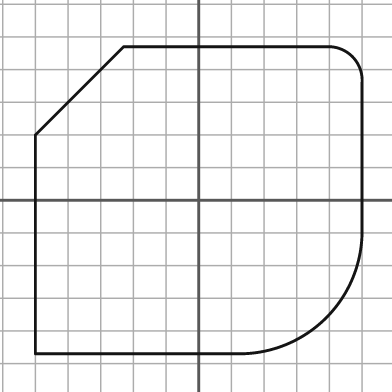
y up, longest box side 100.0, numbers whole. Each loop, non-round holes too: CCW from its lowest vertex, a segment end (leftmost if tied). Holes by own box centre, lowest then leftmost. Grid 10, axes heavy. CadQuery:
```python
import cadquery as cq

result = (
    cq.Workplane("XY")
    .moveTo(-50.0, -47.0)
    .lineTo(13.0, -47.0)
    .threePointArc((39.0, -36.0), (50.0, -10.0))
    .lineTo(50.0, 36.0)
    .threePointArc((47.0, 44.0), (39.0, 47.0))
    .lineTo(-23.0, 47.0)
    .lineTo(-50.0, 20.0)
    .close()
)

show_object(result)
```